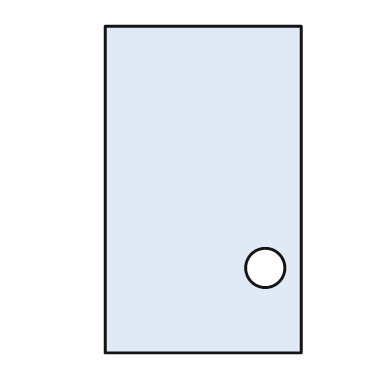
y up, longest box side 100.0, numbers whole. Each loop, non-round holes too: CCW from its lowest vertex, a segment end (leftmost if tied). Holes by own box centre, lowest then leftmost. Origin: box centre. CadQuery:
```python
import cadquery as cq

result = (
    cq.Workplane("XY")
    .moveTo(-30.0, -50.0)
    .lineTo(30.0, -50.0)
    .lineTo(30.0, 50.0)
    .lineTo(-30.0, 50.0)
    .close()
    .moveTo(19.0, -24.0)
    .circle(6.0)
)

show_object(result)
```